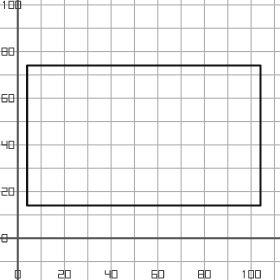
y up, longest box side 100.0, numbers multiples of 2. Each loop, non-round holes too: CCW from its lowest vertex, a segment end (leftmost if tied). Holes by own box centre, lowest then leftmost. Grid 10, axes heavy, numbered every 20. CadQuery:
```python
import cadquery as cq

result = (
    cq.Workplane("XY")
    .moveTo(4.0, 14.0)
    .lineTo(104.0, 14.0)
    .lineTo(104.0, 74.0)
    .lineTo(4.0, 74.0)
    .close()
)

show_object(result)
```